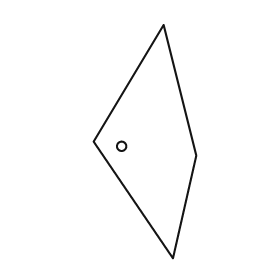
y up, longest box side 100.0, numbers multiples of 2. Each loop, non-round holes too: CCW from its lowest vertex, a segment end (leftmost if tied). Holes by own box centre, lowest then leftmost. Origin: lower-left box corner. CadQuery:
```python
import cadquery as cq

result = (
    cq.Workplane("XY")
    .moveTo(34.0, 0.0)
    .lineTo(44.0, 44.0)
    .lineTo(30.0, 100.0)
    .lineTo(0.0, 50.0)
    .close()
    .moveTo(12.0, 48.0)
    .circle(2.0)
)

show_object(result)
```